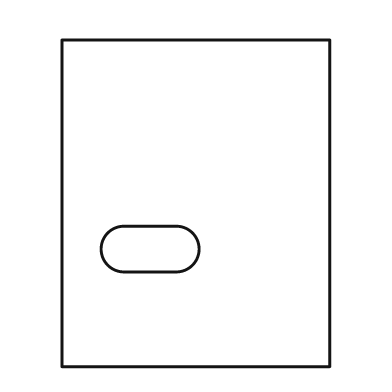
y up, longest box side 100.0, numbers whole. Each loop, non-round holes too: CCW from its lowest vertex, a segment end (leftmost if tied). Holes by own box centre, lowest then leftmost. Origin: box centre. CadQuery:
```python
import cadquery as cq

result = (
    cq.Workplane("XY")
    .moveTo(-41.0, -50.0)
    .lineTo(41.0, -50.0)
    .lineTo(41.0, 50.0)
    .lineTo(-41.0, 50.0)
    .close()
    .moveTo(-22.0, -21.0)
    .lineTo(-6.0, -21.0)
    .threePointArc((1.0, -14.0), (-6.0, -7.0))
    .lineTo(-22.0, -7.0)
    .threePointArc((-29.0, -14.0), (-22.0, -21.0))
    .close()
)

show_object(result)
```